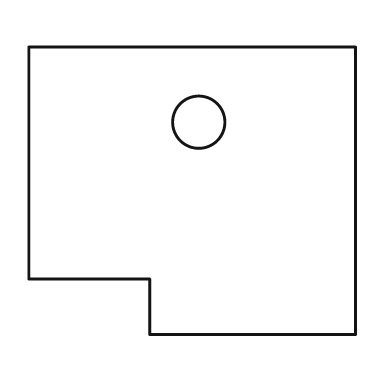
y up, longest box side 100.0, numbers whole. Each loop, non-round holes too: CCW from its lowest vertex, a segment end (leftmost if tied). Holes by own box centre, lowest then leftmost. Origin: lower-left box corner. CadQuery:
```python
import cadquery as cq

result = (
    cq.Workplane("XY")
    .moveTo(37.0, 0.0)
    .lineTo(100.0, 0.0)
    .lineTo(100.0, 88.0)
    .lineTo(0.0, 88.0)
    .lineTo(0.0, 17.0)
    .lineTo(37.0, 17.0)
    .close()
    .moveTo(52.0, 65.0)
    .circle(8.0)
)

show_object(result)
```